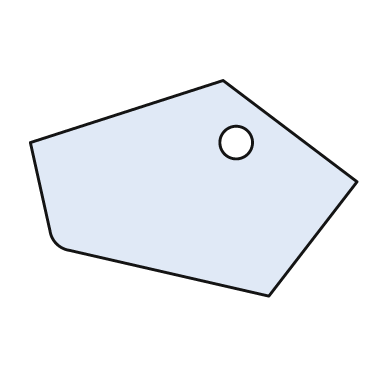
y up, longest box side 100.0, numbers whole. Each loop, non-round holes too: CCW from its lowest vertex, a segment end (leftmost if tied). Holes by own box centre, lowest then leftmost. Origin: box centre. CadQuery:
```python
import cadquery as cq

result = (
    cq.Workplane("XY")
    .moveTo(23.0, -33.0)
    .lineTo(50.0, 2.0)
    .lineTo(9.0, 33.0)
    .lineTo(-50.0, 14.0)
    .lineTo(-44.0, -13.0)
    .threePointArc((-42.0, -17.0), (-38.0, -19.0))
    .close()
    .moveTo(13.0, 14.0)
    .circle(5.0)
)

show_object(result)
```